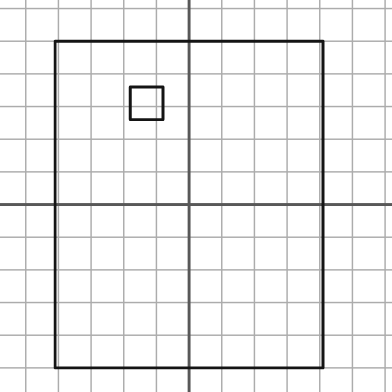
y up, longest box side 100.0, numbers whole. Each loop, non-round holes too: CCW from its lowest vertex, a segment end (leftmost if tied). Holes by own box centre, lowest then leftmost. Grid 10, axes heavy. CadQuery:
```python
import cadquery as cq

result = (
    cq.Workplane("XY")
    .moveTo(-41.0, -50.0)
    .lineTo(41.0, -50.0)
    .lineTo(41.0, 50.0)
    .lineTo(-41.0, 50.0)
    .close()
    .moveTo(-18.0, 26.0)
    .lineTo(-8.0, 26.0)
    .lineTo(-8.0, 36.0)
    .lineTo(-18.0, 36.0)
    .close()
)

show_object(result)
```